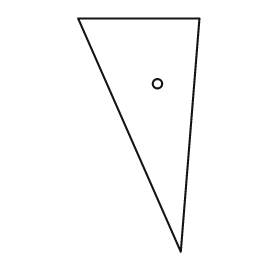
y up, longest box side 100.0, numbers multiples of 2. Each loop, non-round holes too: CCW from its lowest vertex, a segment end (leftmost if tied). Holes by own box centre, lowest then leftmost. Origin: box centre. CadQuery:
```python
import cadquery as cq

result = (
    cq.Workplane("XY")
    .moveTo(18.0, -50.0)
    .lineTo(26.0, 50.0)
    .lineTo(-26.0, 50.0)
    .close()
    .moveTo(8.0, 22.0)
    .circle(2.0)
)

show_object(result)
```